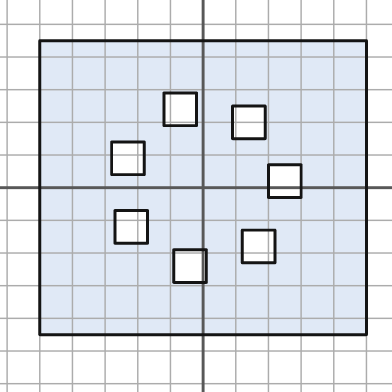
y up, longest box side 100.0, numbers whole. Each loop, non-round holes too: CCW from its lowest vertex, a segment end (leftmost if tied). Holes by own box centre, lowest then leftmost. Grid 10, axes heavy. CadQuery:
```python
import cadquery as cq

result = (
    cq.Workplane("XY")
    .moveTo(-50.0, -45.0)
    .lineTo(50.0, -45.0)
    .lineTo(50.0, 45.0)
    .lineTo(-50.0, 45.0)
    .close()
    .moveTo(-9.0, -29.0)
    .lineTo(1.0, -29.0)
    .lineTo(1.0, -19.0)
    .lineTo(-9.0, -19.0)
    .close()
    .moveTo(12.0, -23.0)
    .lineTo(22.0, -23.0)
    .lineTo(22.0, -13.0)
    .lineTo(12.0, -13.0)
    .close()
    .moveTo(-27.0, -17.0)
    .lineTo(-17.0, -17.0)
    .lineTo(-17.0, -7.0)
    .lineTo(-27.0, -7.0)
    .close()
    .moveTo(20.0, -3.0)
    .lineTo(30.0, -3.0)
    .lineTo(30.0, 7.0)
    .lineTo(20.0, 7.0)
    .close()
    .moveTo(-28.0, 4.0)
    .lineTo(-18.0, 4.0)
    .lineTo(-18.0, 14.0)
    .lineTo(-28.0, 14.0)
    .close()
    .moveTo(9.0, 15.0)
    .lineTo(19.0, 15.0)
    .lineTo(19.0, 25.0)
    .lineTo(9.0, 25.0)
    .close()
    .moveTo(-12.0, 19.0)
    .lineTo(-2.0, 19.0)
    .lineTo(-2.0, 29.0)
    .lineTo(-12.0, 29.0)
    .close()
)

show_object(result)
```